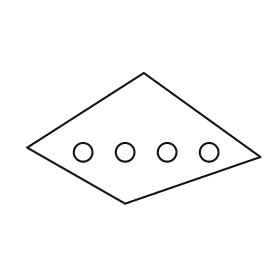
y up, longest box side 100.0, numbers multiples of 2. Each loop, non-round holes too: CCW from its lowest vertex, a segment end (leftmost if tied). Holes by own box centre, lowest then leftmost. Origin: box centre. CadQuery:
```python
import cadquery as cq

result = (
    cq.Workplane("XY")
    .moveTo(-8.0, -28.0)
    .lineTo(50.0, -8.0)
    .lineTo(0.0, 28.0)
    .lineTo(-50.0, -4.0)
    .close()
    .moveTo(-26.0, -6.0)
    .circle(4.0)
    .moveTo(-8.0, -6.0)
    .circle(4.0)
    .moveTo(10.0, -6.0)
    .circle(4.0)
    .moveTo(28.0, -6.0)
    .circle(4.0)
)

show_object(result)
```